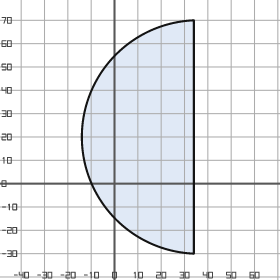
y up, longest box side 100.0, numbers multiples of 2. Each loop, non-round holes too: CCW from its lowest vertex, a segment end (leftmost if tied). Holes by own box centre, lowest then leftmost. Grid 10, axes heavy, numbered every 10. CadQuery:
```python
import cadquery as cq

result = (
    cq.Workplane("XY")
    .moveTo(34.0, -30.0)
    .lineTo(34.0, 70.0)
    .threePointArc((-14.0, 20.0), (34.0, -30.0))
    .close()
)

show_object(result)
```